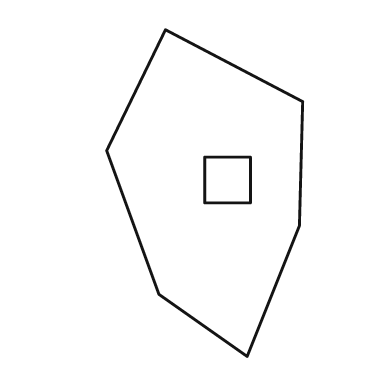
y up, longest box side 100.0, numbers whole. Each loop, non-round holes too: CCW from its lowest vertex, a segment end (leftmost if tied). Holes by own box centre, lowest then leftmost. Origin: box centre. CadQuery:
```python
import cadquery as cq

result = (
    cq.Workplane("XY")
    .moveTo(13.0, -50.0)
    .lineTo(29.0, -10.0)
    .lineTo(30.0, 28.0)
    .lineTo(-12.0, 50.0)
    .lineTo(-30.0, 13.0)
    .lineTo(-14.0, -31.0)
    .close()
    .moveTo(0.0, -3.0)
    .lineTo(14.0, -3.0)
    .lineTo(14.0, 11.0)
    .lineTo(0.0, 11.0)
    .close()
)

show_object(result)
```